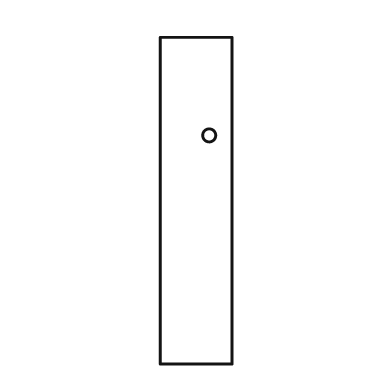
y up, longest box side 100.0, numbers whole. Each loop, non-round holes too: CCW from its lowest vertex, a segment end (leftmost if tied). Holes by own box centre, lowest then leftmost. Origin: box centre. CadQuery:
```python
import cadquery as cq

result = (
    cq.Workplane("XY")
    .moveTo(-11.0, -50.0)
    .lineTo(11.0, -50.0)
    .lineTo(11.0, 50.0)
    .lineTo(-11.0, 50.0)
    .close()
    .moveTo(4.0, 20.0)
    .circle(2.0)
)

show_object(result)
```